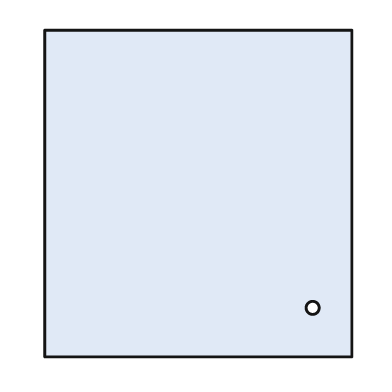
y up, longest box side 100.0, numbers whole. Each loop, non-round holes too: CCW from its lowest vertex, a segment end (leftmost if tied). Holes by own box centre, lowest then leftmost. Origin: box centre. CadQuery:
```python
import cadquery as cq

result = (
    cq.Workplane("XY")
    .moveTo(-47.0, -50.0)
    .lineTo(47.0, -50.0)
    .lineTo(47.0, 50.0)
    .lineTo(-47.0, 50.0)
    .close()
    .moveTo(35.0, -35.0)
    .circle(2.0)
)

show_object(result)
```